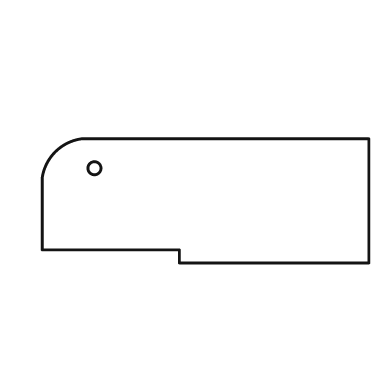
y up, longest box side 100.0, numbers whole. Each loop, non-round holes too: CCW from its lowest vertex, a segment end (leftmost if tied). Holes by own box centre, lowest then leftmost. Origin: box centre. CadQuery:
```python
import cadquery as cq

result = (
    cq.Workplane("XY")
    .moveTo(-8.0, -19.0)
    .lineTo(50.0, -19.0)
    .lineTo(50.0, 19.0)
    .lineTo(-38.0, 19.0)
    .threePointArc((-46.0, 15.0), (-50.0, 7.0))
    .lineTo(-50.0, -15.0)
    .lineTo(-8.0, -15.0)
    .close()
    .moveTo(-34.0, 10.0)
    .circle(2.0)
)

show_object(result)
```